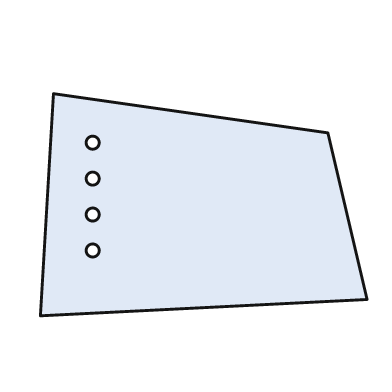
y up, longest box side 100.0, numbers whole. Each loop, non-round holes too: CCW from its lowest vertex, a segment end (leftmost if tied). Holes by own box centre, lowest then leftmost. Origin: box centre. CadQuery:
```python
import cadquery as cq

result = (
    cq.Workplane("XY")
    .moveTo(-50.0, -34.0)
    .lineTo(50.0, -29.0)
    .lineTo(38.0, 22.0)
    .lineTo(-46.0, 34.0)
    .close()
    .moveTo(-34.0, -14.0)
    .circle(2.0)
    .moveTo(-34.0, -3.0)
    .circle(2.0)
    .moveTo(-34.0, 8.0)
    .circle(2.0)
    .moveTo(-34.0, 19.0)
    .circle(2.0)
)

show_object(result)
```